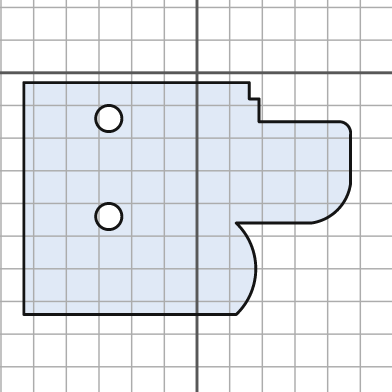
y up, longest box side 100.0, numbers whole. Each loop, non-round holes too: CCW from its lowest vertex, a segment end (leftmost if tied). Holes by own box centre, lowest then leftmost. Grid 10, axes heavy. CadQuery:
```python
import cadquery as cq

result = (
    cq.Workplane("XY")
    .moveTo(-53.0, -74.0)
    .lineTo(12.0, -74.0)
    .threePointArc((18.0, -60.0), (12.0, -46.0))
    .lineTo(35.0, -46.0)
    .threePointArc((43.0, -42.0), (47.0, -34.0))
    .lineTo(47.0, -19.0)
    .threePointArc((46.0, -16.0), (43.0, -15.0))
    .lineTo(19.0, -15.0)
    .lineTo(19.0, -8.0)
    .lineTo(16.0, -8.0)
    .lineTo(16.0, -3.0)
    .lineTo(-53.0, -3.0)
    .close()
    .moveTo(-27.0, -44.0)
    .circle(4.0)
    .moveTo(-27.0, -14.0)
    .circle(4.0)
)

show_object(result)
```